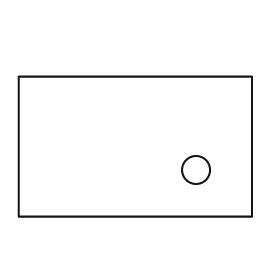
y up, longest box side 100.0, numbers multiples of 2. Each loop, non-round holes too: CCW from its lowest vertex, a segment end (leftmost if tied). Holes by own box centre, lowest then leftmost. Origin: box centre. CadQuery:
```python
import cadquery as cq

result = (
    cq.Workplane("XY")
    .moveTo(-50.0, -30.0)
    .lineTo(50.0, -30.0)
    .lineTo(50.0, 30.0)
    .lineTo(-50.0, 30.0)
    .close()
    .moveTo(26.0, -10.0)
    .circle(6.0)
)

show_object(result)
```